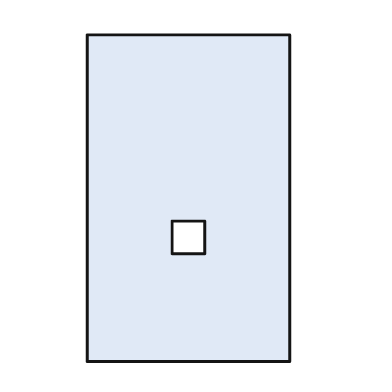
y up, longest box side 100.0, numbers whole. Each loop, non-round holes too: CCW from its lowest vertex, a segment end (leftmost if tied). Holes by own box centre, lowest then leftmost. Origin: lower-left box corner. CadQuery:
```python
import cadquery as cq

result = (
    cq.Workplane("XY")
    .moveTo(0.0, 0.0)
    .lineTo(62.0, 0.0)
    .lineTo(62.0, 100.0)
    .lineTo(0.0, 100.0)
    .close()
    .moveTo(26.0, 33.0)
    .lineTo(36.0, 33.0)
    .lineTo(36.0, 43.0)
    .lineTo(26.0, 43.0)
    .close()
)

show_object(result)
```